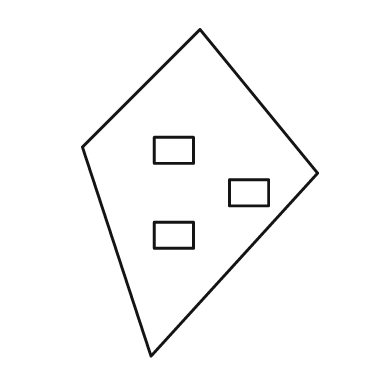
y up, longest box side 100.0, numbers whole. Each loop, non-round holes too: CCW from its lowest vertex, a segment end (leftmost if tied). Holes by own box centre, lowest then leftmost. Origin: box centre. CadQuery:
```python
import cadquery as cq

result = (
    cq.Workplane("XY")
    .moveTo(-15.0, -50.0)
    .lineTo(36.0, 6.0)
    .lineTo(0.0, 50.0)
    .lineTo(-36.0, 14.0)
    .close()
    .moveTo(-14.0, -17.0)
    .lineTo(-2.0, -17.0)
    .lineTo(-2.0, -9.0)
    .lineTo(-14.0, -9.0)
    .close()
    .moveTo(9.0, -4.0)
    .lineTo(21.0, -4.0)
    .lineTo(21.0, 4.0)
    .lineTo(9.0, 4.0)
    .close()
    .moveTo(-14.0, 9.0)
    .lineTo(-2.0, 9.0)
    .lineTo(-2.0, 17.0)
    .lineTo(-14.0, 17.0)
    .close()
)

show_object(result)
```